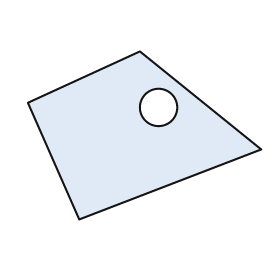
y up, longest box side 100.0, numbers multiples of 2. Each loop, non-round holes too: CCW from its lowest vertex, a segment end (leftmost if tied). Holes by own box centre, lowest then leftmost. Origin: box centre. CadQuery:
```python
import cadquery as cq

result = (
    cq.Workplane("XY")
    .moveTo(-28.0, -36.0)
    .lineTo(50.0, -6.0)
    .lineTo(-2.0, 36.0)
    .lineTo(-50.0, 14.0)
    .close()
    .moveTo(6.0, 12.0)
    .circle(8.0)
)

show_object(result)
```